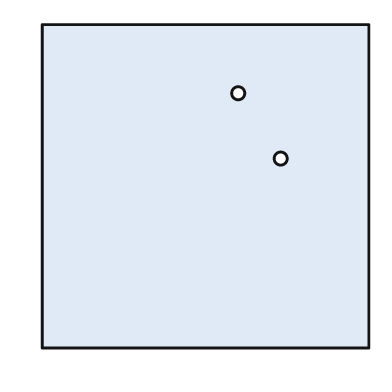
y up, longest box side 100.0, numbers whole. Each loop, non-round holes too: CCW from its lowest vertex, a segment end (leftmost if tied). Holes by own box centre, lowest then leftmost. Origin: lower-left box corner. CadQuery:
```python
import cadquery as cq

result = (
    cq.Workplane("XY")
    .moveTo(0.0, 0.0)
    .lineTo(100.0, 0.0)
    .lineTo(100.0, 99.0)
    .lineTo(0.0, 99.0)
    .close()
    .moveTo(73.0, 58.0)
    .circle(2.0)
    .moveTo(60.0, 78.0)
    .circle(2.0)
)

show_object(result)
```